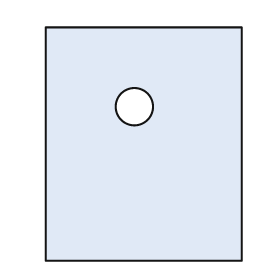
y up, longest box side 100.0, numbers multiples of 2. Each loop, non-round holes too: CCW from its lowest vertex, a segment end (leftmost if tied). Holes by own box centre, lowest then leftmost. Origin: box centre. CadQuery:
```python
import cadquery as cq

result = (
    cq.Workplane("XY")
    .moveTo(-42.0, -50.0)
    .lineTo(42.0, -50.0)
    .lineTo(42.0, 50.0)
    .lineTo(-42.0, 50.0)
    .close()
    .moveTo(-4.0, 16.0)
    .circle(8.0)
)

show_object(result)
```